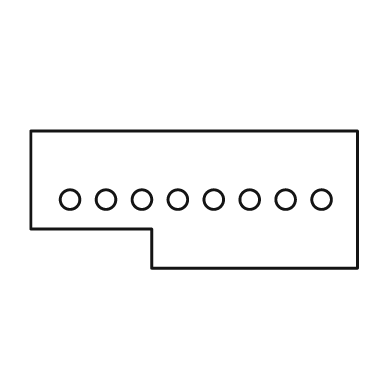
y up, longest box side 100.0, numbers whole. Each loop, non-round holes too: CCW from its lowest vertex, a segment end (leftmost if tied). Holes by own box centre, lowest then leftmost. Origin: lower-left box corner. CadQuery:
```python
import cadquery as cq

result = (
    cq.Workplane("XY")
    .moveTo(37.0, 0.0)
    .lineTo(100.0, 0.0)
    .lineTo(100.0, 42.0)
    .lineTo(0.0, 42.0)
    .lineTo(0.0, 12.0)
    .lineTo(37.0, 12.0)
    .close()
    .moveTo(12.0, 21.0)
    .circle(3.0)
    .moveTo(23.0, 21.0)
    .circle(3.0)
    .moveTo(34.0, 21.0)
    .circle(3.0)
    .moveTo(45.0, 21.0)
    .circle(3.0)
    .moveTo(56.0, 21.0)
    .circle(3.0)
    .moveTo(67.0, 21.0)
    .circle(3.0)
    .moveTo(78.0, 21.0)
    .circle(3.0)
    .moveTo(89.0, 21.0)
    .circle(3.0)
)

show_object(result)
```